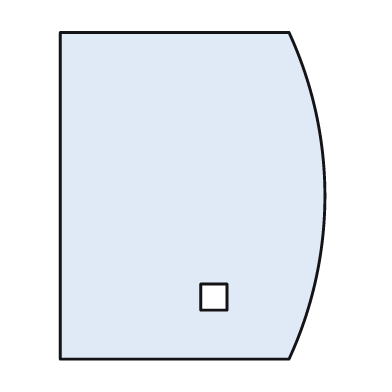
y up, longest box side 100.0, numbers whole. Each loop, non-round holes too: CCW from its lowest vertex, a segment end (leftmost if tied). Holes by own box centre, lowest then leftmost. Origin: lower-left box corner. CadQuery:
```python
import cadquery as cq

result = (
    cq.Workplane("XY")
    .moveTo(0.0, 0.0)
    .lineTo(70.0, 0.0)
    .threePointArc((81.0, 50.0), (70.0, 100.0))
    .lineTo(0.0, 100.0)
    .close()
    .moveTo(43.0, 15.0)
    .lineTo(51.0, 15.0)
    .lineTo(51.0, 23.0)
    .lineTo(43.0, 23.0)
    .close()
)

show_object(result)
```